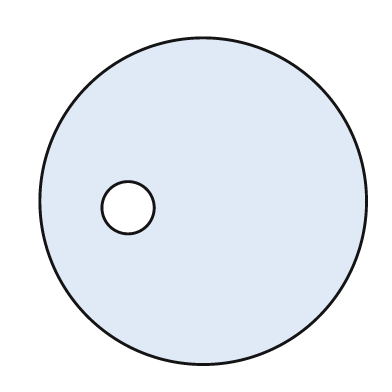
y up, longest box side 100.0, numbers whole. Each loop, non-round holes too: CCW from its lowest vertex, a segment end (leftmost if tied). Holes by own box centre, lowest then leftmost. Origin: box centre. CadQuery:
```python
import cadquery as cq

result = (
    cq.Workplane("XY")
    .moveTo(0.0, 0.0)
    .circle(50.0)
    .moveTo(-23.0, -2.0)
    .circle(8.0)
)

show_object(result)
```